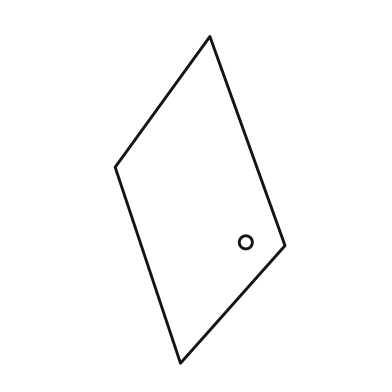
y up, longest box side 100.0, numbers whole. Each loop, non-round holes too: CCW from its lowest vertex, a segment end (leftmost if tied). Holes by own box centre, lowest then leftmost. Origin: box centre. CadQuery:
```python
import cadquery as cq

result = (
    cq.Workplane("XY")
    .moveTo(-6.0, -50.0)
    .lineTo(26.0, -14.0)
    .lineTo(3.0, 50.0)
    .lineTo(-26.0, 10.0)
    .close()
    .moveTo(14.0, -13.0)
    .circle(2.0)
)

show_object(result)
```